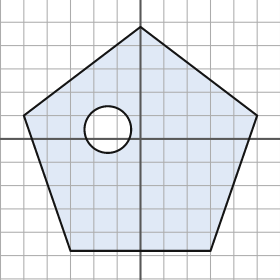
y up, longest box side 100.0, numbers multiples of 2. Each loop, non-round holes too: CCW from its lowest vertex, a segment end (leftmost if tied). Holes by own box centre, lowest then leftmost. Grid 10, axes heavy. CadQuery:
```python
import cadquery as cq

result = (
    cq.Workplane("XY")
    .moveTo(-30.0, -48.0)
    .lineTo(30.0, -48.0)
    .lineTo(50.0, 10.0)
    .lineTo(0.0, 48.0)
    .lineTo(-50.0, 10.0)
    .close()
    .moveTo(-14.0, 4.0)
    .circle(10.0)
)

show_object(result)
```